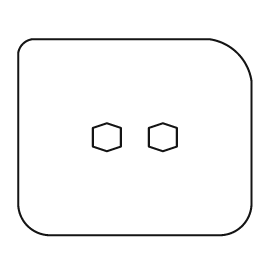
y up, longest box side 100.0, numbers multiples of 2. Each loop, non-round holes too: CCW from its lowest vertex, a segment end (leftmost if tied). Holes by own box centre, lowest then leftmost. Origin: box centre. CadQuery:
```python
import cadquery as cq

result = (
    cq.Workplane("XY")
    .moveTo(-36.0, -42.0)
    .lineTo(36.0, -42.0)
    .threePointArc((46.0, -38.0), (50.0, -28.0))
    .lineTo(50.0, 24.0)
    .threePointArc((44.0, 36.0), (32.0, 42.0))
    .lineTo(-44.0, 42.0)
    .threePointArc((-48.0, 40.0), (-50.0, 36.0))
    .lineTo(-50.0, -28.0)
    .threePointArc((-46.0, -38.0), (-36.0, -42.0))
    .close()
    .moveTo(-12.0, -6.0)
    .lineTo(-6.0, -4.0)
    .lineTo(-6.0, 4.0)
    .lineTo(-12.0, 6.0)
    .lineTo(-18.0, 4.0)
    .lineTo(-18.0, -4.0)
    .close()
    .moveTo(12.0, -6.0)
    .lineTo(18.0, -4.0)
    .lineTo(18.0, 4.0)
    .lineTo(12.0, 6.0)
    .lineTo(6.0, 4.0)
    .lineTo(6.0, -4.0)
    .close()
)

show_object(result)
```